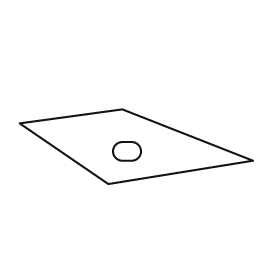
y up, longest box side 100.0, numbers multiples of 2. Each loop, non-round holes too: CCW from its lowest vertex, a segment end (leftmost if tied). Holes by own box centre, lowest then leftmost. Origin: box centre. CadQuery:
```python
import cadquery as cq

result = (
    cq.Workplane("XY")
    .moveTo(-12.0, -16.0)
    .lineTo(50.0, -6.0)
    .lineTo(-6.0, 16.0)
    .lineTo(-50.0, 10.0)
    .close()
    .moveTo(-6.0, -6.0)
    .lineTo(-2.0, -6.0)
    .threePointArc((2.0, -2.0), (-2.0, 2.0))
    .lineTo(-6.0, 2.0)
    .threePointArc((-10.0, -2.0), (-6.0, -6.0))
    .close()
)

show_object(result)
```